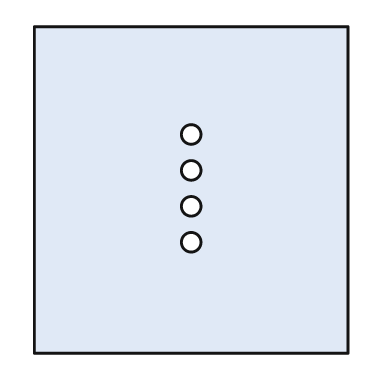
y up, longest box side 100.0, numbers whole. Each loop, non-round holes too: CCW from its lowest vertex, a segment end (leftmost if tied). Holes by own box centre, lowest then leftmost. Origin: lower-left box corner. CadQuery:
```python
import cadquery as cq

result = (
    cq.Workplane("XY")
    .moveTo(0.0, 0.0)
    .lineTo(96.0, 0.0)
    .lineTo(96.0, 100.0)
    .lineTo(0.0, 100.0)
    .close()
    .moveTo(48.0, 34.0)
    .circle(3.0)
    .moveTo(48.0, 45.0)
    .circle(3.0)
    .moveTo(48.0, 56.0)
    .circle(3.0)
    .moveTo(48.0, 67.0)
    .circle(3.0)
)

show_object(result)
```